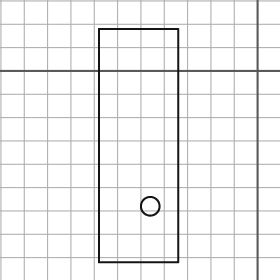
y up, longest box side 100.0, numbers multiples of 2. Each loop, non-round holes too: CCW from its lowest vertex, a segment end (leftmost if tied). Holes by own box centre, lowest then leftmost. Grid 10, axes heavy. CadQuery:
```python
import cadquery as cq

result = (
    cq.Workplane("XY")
    .moveTo(-68.0, -82.0)
    .lineTo(-34.0, -82.0)
    .lineTo(-34.0, 18.0)
    .lineTo(-68.0, 18.0)
    .close()
    .moveTo(-46.0, -58.0)
    .circle(4.0)
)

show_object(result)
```